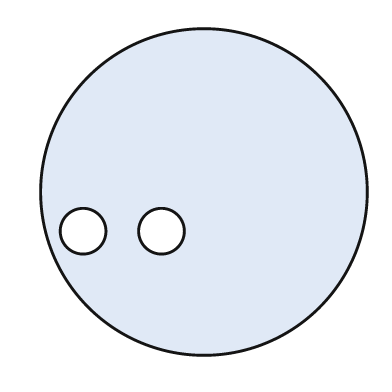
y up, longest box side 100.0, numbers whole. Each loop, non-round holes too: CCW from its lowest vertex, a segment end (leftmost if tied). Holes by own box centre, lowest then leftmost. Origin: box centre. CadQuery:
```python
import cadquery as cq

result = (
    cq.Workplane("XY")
    .moveTo(0.0, 0.0)
    .circle(50.0)
    .moveTo(-37.0, -12.0)
    .circle(7.0)
    .moveTo(-13.0, -12.0)
    .circle(7.0)
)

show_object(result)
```